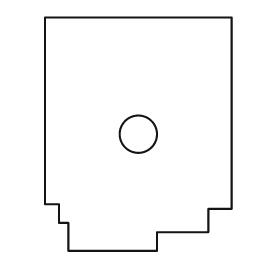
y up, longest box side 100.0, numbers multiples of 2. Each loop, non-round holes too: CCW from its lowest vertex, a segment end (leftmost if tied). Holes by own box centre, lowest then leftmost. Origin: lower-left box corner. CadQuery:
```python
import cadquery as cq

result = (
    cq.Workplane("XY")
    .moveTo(10.0, 0.0)
    .lineTo(48.0, 0.0)
    .lineTo(48.0, 8.0)
    .lineTo(70.0, 8.0)
    .lineTo(70.0, 18.0)
    .lineTo(80.0, 18.0)
    .lineTo(80.0, 100.0)
    .lineTo(0.0, 100.0)
    .lineTo(0.0, 20.0)
    .lineTo(6.0, 20.0)
    .lineTo(6.0, 12.0)
    .lineTo(10.0, 12.0)
    .close()
    .moveTo(40.0, 50.0)
    .circle(8.0)
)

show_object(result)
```